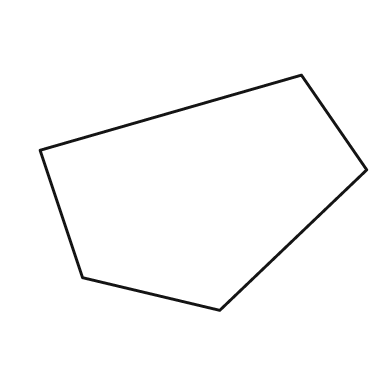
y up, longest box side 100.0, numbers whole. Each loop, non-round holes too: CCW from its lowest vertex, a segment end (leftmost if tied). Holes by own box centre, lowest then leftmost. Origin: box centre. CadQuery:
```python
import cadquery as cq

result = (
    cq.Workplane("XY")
    .moveTo(5.0, -36.0)
    .lineTo(50.0, 7.0)
    .lineTo(30.0, 36.0)
    .lineTo(-50.0, 13.0)
    .lineTo(-37.0, -26.0)
    .close()
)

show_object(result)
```